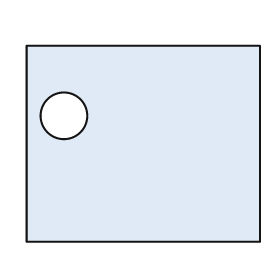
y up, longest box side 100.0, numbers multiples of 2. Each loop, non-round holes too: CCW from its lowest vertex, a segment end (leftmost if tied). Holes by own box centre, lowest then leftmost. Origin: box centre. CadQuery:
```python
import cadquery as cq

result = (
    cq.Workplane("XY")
    .moveTo(-50.0, -42.0)
    .lineTo(50.0, -42.0)
    .lineTo(50.0, 42.0)
    .lineTo(-50.0, 42.0)
    .close()
    .moveTo(-34.0, 12.0)
    .circle(10.0)
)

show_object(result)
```